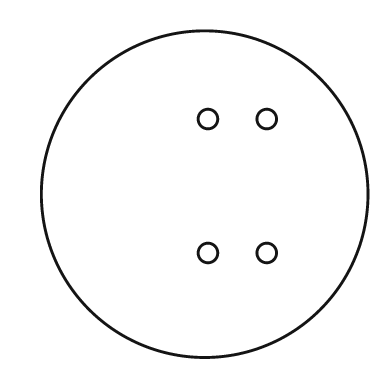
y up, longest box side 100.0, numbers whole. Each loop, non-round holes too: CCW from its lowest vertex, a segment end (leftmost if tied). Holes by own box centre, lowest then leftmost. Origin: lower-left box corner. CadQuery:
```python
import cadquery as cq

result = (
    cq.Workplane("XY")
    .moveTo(50.0, 50.0)
    .circle(50.0)
    .moveTo(51.0, 32.0)
    .circle(3.0)
    .moveTo(69.0, 32.0)
    .circle(3.0)
    .moveTo(51.0, 73.0)
    .circle(3.0)
    .moveTo(69.0, 73.0)
    .circle(3.0)
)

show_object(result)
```